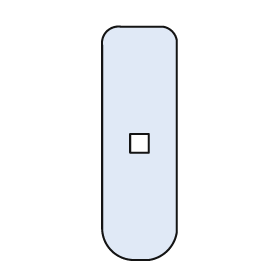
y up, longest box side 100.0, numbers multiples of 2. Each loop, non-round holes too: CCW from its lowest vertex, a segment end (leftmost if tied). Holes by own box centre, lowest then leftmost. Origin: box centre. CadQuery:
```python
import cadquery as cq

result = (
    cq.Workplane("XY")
    .moveTo(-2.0, -50.0)
    .lineTo(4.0, -50.0)
    .threePointArc((12.0, -46.0), (16.0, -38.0))
    .lineTo(16.0, 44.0)
    .threePointArc((14.0, 48.0), (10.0, 50.0))
    .lineTo(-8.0, 50.0)
    .threePointArc((-14.0, 48.0), (-16.0, 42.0))
    .lineTo(-16.0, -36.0)
    .threePointArc((-12.0, -46.0), (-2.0, -50.0))
    .close()
    .moveTo(-4.0, -4.0)
    .lineTo(4.0, -4.0)
    .lineTo(4.0, 4.0)
    .lineTo(-4.0, 4.0)
    .close()
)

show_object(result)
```